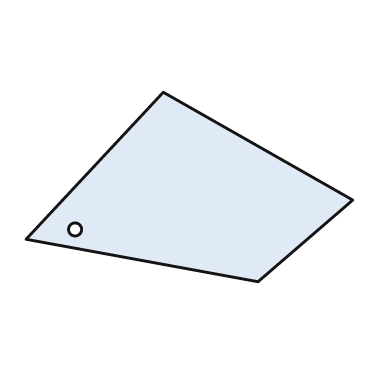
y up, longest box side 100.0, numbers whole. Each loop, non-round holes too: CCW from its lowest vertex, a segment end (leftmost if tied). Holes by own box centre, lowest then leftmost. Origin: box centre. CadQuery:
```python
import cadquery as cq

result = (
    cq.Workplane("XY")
    .moveTo(21.0, -29.0)
    .lineTo(50.0, -4.0)
    .lineTo(-8.0, 29.0)
    .lineTo(-50.0, -16.0)
    .close()
    .moveTo(-35.0, -13.0)
    .circle(2.0)
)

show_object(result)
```